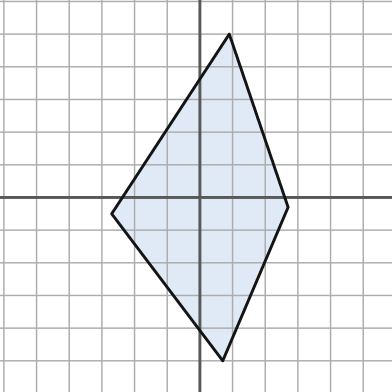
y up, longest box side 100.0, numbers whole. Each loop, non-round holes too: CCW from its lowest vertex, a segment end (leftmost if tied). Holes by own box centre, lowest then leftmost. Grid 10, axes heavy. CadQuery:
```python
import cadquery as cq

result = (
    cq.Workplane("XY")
    .moveTo(7.0, -50.0)
    .lineTo(27.0, -3.0)
    .lineTo(9.0, 50.0)
    .lineTo(-27.0, -5.0)
    .close()
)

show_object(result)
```